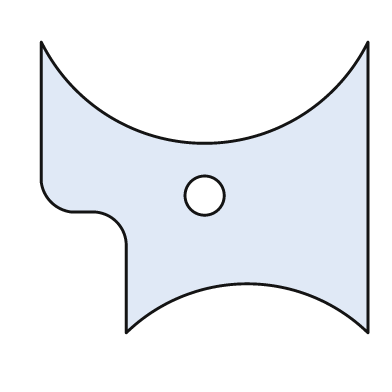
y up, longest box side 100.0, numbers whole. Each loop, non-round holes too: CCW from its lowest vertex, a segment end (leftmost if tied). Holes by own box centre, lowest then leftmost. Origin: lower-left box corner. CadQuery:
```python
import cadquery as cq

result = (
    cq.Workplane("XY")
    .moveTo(26.0, 0.0)
    .threePointArc((63.0, 15.0), (100.0, 0.0))
    .lineTo(100.0, 89.0)
    .threePointArc((50.0, 58.0), (0.0, 89.0))
    .lineTo(0.0, 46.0)
    .threePointArc((3.0, 40.0), (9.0, 37.0))
    .lineTo(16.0, 37.0)
    .threePointArc((23.0, 34.0), (26.0, 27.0))
    .close()
    .moveTo(50.0, 42.0)
    .circle(6.0)
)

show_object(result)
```